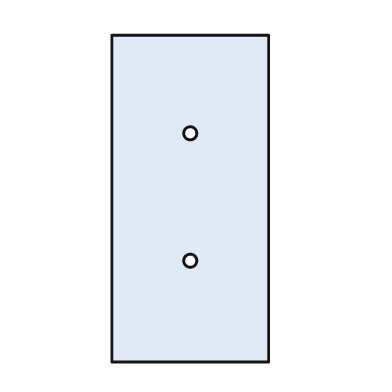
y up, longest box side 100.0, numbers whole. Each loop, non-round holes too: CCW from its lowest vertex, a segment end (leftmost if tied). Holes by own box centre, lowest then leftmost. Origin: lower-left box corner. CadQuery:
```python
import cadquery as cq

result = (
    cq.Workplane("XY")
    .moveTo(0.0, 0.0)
    .lineTo(48.0, 0.0)
    .lineTo(48.0, 100.0)
    .lineTo(0.0, 100.0)
    .close()
    .moveTo(24.0, 31.0)
    .circle(2.0)
    .moveTo(24.0, 70.0)
    .circle(2.0)
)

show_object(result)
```